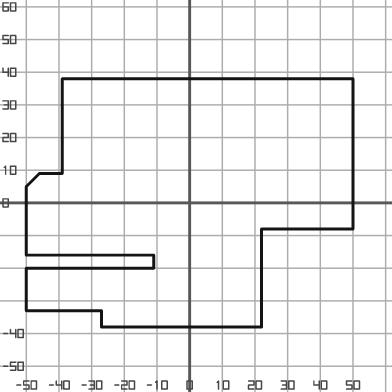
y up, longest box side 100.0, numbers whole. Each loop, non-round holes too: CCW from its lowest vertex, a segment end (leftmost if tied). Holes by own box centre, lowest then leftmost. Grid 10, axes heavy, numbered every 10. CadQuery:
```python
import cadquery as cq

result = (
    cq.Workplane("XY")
    .moveTo(-27.0, -38.0)
    .lineTo(22.0, -38.0)
    .lineTo(22.0, -8.0)
    .lineTo(50.0, -8.0)
    .lineTo(50.0, 38.0)
    .lineTo(-39.0, 38.0)
    .lineTo(-39.0, 9.0)
    .lineTo(-46.0, 9.0)
    .lineTo(-50.0, 5.0)
    .lineTo(-50.0, -16.0)
    .lineTo(-11.0, -16.0)
    .lineTo(-11.0, -20.0)
    .lineTo(-50.0, -20.0)
    .lineTo(-50.0, -33.0)
    .lineTo(-27.0, -33.0)
    .close()
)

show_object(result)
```